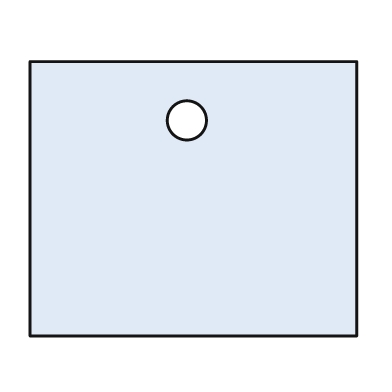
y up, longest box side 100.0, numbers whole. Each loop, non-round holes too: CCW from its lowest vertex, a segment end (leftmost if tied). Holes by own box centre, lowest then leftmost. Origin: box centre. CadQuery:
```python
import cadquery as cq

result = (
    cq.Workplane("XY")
    .moveTo(-50.0, -42.0)
    .lineTo(50.0, -42.0)
    .lineTo(50.0, 42.0)
    .lineTo(-50.0, 42.0)
    .close()
    .moveTo(-2.0, 24.0)
    .circle(6.0)
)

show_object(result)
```